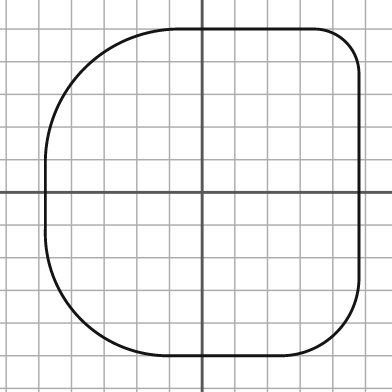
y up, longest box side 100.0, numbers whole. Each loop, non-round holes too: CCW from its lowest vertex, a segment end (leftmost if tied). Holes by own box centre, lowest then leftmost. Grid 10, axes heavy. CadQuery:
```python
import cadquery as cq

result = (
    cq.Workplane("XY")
    .moveTo(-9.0, -50.0)
    .lineTo(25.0, -50.0)
    .threePointArc((41.0, -43.0), (48.0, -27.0))
    .lineTo(48.0, 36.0)
    .threePointArc((44.0, 46.0), (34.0, 50.0))
    .lineTo(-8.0, 50.0)
    .threePointArc((-36.0, 38.0), (-48.0, 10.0))
    .lineTo(-48.0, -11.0)
    .threePointArc((-37.0, -39.0), (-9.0, -50.0))
    .close()
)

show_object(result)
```